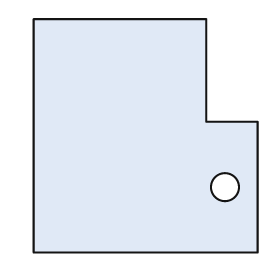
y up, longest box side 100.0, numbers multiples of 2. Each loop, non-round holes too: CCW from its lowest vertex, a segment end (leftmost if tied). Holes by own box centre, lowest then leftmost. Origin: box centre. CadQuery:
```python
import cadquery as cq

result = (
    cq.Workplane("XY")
    .moveTo(-48.0, -50.0)
    .lineTo(48.0, -50.0)
    .lineTo(48.0, 6.0)
    .lineTo(26.0, 6.0)
    .lineTo(26.0, 50.0)
    .lineTo(-48.0, 50.0)
    .close()
    .moveTo(34.0, -22.0)
    .circle(6.0)
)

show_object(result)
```